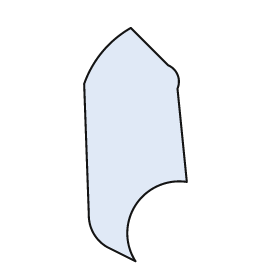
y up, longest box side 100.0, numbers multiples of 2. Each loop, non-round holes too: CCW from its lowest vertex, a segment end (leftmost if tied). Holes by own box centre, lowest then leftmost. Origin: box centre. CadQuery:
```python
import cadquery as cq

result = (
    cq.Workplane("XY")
    .moveTo(0.0, -50.0)
    .threePointArc((0.0, -26.0), (22.0, -16.0))
    .lineTo(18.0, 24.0)
    .threePointArc((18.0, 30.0), (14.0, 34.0))
    .lineTo(-2.0, 50.0)
    .threePointArc((-14.0, 40.0), (-22.0, 26.0))
    .lineTo(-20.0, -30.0)
    .threePointArc((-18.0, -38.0), (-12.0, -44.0))
    .close()
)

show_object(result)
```